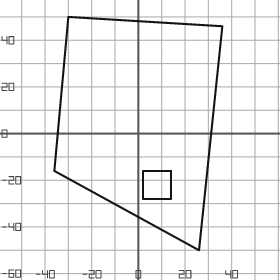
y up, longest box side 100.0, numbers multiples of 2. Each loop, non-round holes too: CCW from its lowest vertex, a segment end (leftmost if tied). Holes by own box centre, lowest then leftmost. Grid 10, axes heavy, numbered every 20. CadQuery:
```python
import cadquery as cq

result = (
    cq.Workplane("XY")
    .moveTo(26.0, -50.0)
    .lineTo(36.0, 46.0)
    .lineTo(-30.0, 50.0)
    .lineTo(-36.0, -16.0)
    .close()
    .moveTo(2.0, -28.0)
    .lineTo(14.0, -28.0)
    .lineTo(14.0, -16.0)
    .lineTo(2.0, -16.0)
    .close()
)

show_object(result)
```